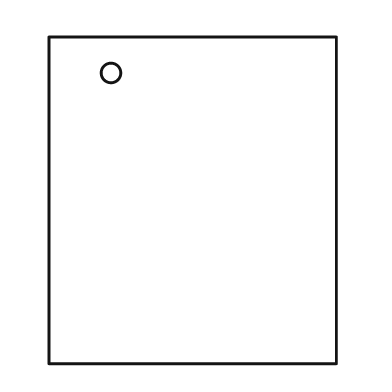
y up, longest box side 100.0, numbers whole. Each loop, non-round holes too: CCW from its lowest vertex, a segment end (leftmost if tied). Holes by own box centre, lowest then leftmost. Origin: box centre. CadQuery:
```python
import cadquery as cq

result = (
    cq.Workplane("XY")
    .moveTo(-44.0, -50.0)
    .lineTo(44.0, -50.0)
    .lineTo(44.0, 50.0)
    .lineTo(-44.0, 50.0)
    .close()
    .moveTo(-25.0, 39.0)
    .circle(3.0)
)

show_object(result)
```